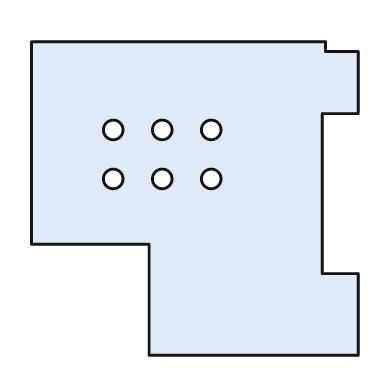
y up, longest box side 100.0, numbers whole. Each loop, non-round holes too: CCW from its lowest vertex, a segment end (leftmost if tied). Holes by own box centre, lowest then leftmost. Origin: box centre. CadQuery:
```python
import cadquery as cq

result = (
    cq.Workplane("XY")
    .moveTo(-14.0, -48.0)
    .lineTo(50.0, -48.0)
    .lineTo(50.0, -23.0)
    .lineTo(39.0, -23.0)
    .lineTo(39.0, 26.0)
    .lineTo(50.0, 26.0)
    .lineTo(50.0, 45.0)
    .lineTo(40.0, 45.0)
    .lineTo(40.0, 48.0)
    .lineTo(-50.0, 48.0)
    .lineTo(-50.0, -14.0)
    .lineTo(-14.0, -14.0)
    .close()
    .moveTo(-25.0, 6.0)
    .circle(3.0)
    .moveTo(-10.0, 6.0)
    .circle(3.0)
    .moveTo(5.0, 6.0)
    .circle(3.0)
    .moveTo(-25.0, 21.0)
    .circle(3.0)
    .moveTo(-10.0, 21.0)
    .circle(3.0)
    .moveTo(5.0, 21.0)
    .circle(3.0)
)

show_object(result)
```